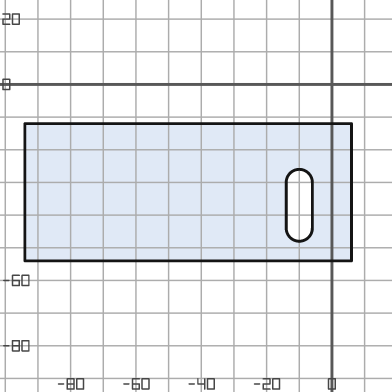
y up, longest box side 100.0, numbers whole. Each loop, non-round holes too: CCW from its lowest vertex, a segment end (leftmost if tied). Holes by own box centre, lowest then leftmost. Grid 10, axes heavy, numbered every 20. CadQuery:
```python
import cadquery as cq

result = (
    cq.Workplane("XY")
    .moveTo(-94.0, -54.0)
    .lineTo(6.0, -54.0)
    .lineTo(6.0, -12.0)
    .lineTo(-94.0, -12.0)
    .close()
    .moveTo(-14.0, -44.0)
    .threePointArc((-10.0, -48.0), (-6.0, -44.0))
    .lineTo(-6.0, -30.0)
    .threePointArc((-10.0, -26.0), (-14.0, -30.0))
    .close()
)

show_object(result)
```